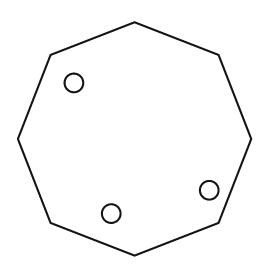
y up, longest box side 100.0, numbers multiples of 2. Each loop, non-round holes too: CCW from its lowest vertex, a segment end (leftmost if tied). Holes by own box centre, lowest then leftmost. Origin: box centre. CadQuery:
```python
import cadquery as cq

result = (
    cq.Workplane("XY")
    .moveTo(0.0, -50.0)
    .lineTo(36.0, -36.0)
    .lineTo(50.0, 0.0)
    .lineTo(36.0, 36.0)
    .lineTo(0.0, 50.0)
    .lineTo(-36.0, 36.0)
    .lineTo(-50.0, 0.0)
    .lineTo(-36.0, -36.0)
    .close()
    .moveTo(-10.0, -32.0)
    .circle(4.0)
    .moveTo(32.0, -22.0)
    .circle(4.0)
    .moveTo(-26.0, 24.0)
    .circle(4.0)
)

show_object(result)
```